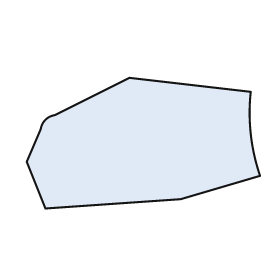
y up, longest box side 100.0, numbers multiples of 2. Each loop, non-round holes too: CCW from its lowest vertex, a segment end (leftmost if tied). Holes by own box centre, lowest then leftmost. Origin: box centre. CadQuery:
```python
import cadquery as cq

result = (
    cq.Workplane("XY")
    .moveTo(-42.0, -28.0)
    .lineTo(16.0, -24.0)
    .lineTo(50.0, -14.0)
    .threePointArc((46.0, 4.0), (46.0, 22.0))
    .lineTo(-6.0, 28.0)
    .lineTo(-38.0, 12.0)
    .threePointArc((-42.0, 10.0), (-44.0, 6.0))
    .lineTo(-50.0, -8.0)
    .close()
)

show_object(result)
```